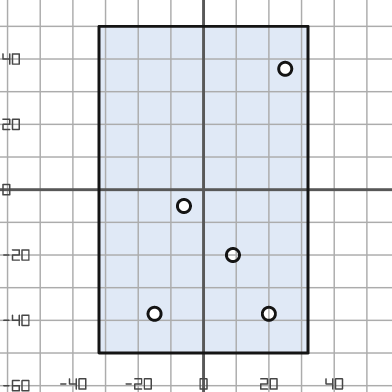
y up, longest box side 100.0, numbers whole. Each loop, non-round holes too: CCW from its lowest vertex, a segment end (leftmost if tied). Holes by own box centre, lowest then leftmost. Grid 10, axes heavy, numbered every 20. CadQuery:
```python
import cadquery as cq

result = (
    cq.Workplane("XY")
    .moveTo(-32.0, -50.0)
    .lineTo(32.0, -50.0)
    .lineTo(32.0, 50.0)
    .lineTo(-32.0, 50.0)
    .close()
    .moveTo(-15.0, -38.0)
    .circle(2.0)
    .moveTo(20.0, -38.0)
    .circle(2.0)
    .moveTo(9.0, -20.0)
    .circle(2.0)
    .moveTo(-6.0, -5.0)
    .circle(2.0)
    .moveTo(25.0, 37.0)
    .circle(2.0)
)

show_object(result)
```